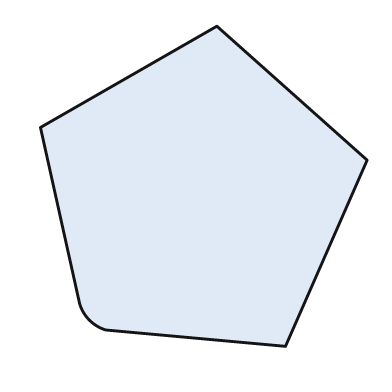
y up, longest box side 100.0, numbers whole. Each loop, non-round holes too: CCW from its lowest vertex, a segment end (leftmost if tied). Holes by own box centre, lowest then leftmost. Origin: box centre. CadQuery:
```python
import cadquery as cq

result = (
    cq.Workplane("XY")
    .moveTo(25.0, -49.0)
    .lineTo(50.0, 8.0)
    .lineTo(4.0, 49.0)
    .lineTo(-50.0, 18.0)
    .lineTo(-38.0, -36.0)
    .threePointArc((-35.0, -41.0), (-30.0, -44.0))
    .close()
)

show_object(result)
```